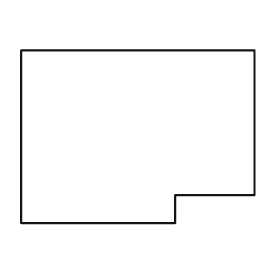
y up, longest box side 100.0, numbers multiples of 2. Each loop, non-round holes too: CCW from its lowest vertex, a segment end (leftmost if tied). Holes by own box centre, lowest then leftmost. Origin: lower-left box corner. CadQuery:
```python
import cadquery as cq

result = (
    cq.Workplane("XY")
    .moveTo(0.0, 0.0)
    .lineTo(66.0, 0.0)
    .lineTo(66.0, 12.0)
    .lineTo(100.0, 12.0)
    .lineTo(100.0, 74.0)
    .lineTo(0.0, 74.0)
    .close()
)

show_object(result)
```